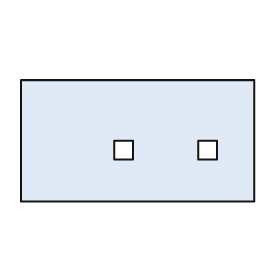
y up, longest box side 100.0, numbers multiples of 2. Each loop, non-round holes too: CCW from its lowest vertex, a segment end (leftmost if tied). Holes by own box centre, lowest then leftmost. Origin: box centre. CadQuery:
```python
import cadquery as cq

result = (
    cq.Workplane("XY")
    .moveTo(-50.0, -26.0)
    .lineTo(50.0, -26.0)
    .lineTo(50.0, 26.0)
    .lineTo(-50.0, 26.0)
    .close()
    .moveTo(-10.0, -8.0)
    .lineTo(-2.0, -8.0)
    .lineTo(-2.0, 0.0)
    .lineTo(-10.0, 0.0)
    .close()
    .moveTo(26.0, -8.0)
    .lineTo(34.0, -8.0)
    .lineTo(34.0, 0.0)
    .lineTo(26.0, 0.0)
    .close()
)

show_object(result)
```